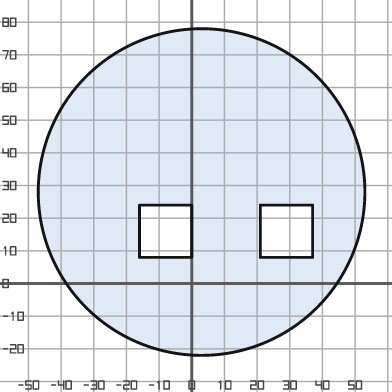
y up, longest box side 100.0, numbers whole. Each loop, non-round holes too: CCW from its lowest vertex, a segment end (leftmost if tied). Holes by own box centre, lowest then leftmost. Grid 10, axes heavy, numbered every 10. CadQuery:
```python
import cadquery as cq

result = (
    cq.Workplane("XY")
    .moveTo(3.0, 28.0)
    .circle(50.0)
    .moveTo(-16.0, 8.0)
    .lineTo(0.0, 8.0)
    .lineTo(0.0, 24.0)
    .lineTo(-16.0, 24.0)
    .close()
    .moveTo(21.0, 8.0)
    .lineTo(37.0, 8.0)
    .lineTo(37.0, 24.0)
    .lineTo(21.0, 24.0)
    .close()
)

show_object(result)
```